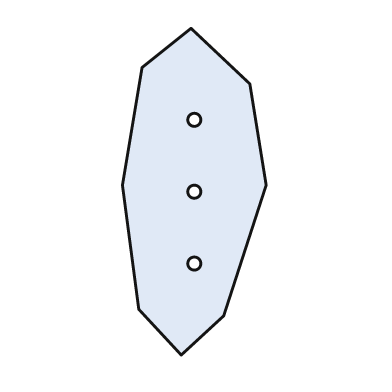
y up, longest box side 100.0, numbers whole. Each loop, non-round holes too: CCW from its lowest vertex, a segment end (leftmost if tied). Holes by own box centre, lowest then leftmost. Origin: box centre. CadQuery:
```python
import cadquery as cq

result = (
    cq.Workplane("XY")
    .moveTo(-4.0, -50.0)
    .lineTo(9.0, -38.0)
    .lineTo(22.0, 2.0)
    .lineTo(17.0, 33.0)
    .lineTo(-1.0, 50.0)
    .lineTo(-16.0, 38.0)
    .lineTo(-22.0, 2.0)
    .lineTo(-17.0, -36.0)
    .close()
    .moveTo(0.0, -22.0)
    .circle(2.0)
    .moveTo(0.0, 0.0)
    .circle(2.0)
    .moveTo(0.0, 22.0)
    .circle(2.0)
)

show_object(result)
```